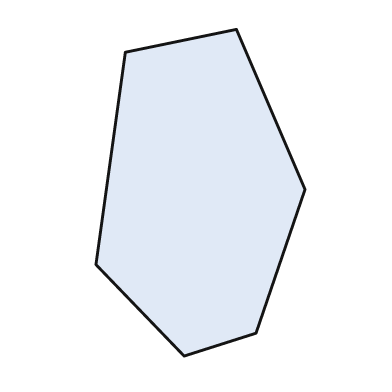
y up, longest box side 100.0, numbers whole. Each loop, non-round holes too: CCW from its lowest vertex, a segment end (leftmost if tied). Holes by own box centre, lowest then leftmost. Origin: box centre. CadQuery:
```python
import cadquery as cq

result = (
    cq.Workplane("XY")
    .moveTo(-5.0, -50.0)
    .lineTo(17.0, -43.0)
    .lineTo(32.0, 1.0)
    .lineTo(11.0, 50.0)
    .lineTo(-23.0, 43.0)
    .lineTo(-32.0, -22.0)
    .close()
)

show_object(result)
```